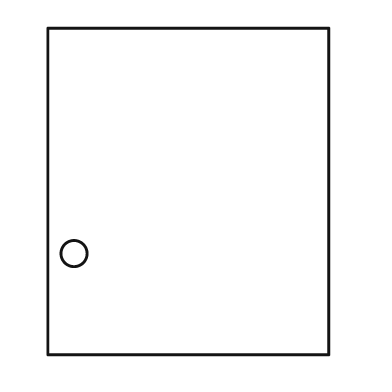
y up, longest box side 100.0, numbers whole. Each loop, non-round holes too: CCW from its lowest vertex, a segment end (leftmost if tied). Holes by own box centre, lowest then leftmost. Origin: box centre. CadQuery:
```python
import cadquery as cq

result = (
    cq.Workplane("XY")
    .moveTo(-43.0, -50.0)
    .lineTo(43.0, -50.0)
    .lineTo(43.0, 50.0)
    .lineTo(-43.0, 50.0)
    .close()
    .moveTo(-35.0, -19.0)
    .circle(4.0)
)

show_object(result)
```